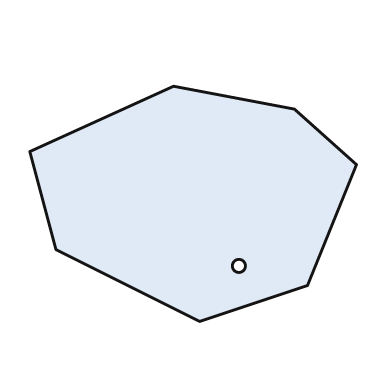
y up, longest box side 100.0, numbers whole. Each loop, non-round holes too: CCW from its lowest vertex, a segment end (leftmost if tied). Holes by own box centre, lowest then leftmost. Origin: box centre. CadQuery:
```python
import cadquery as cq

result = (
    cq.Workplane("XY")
    .moveTo(2.0, -36.0)
    .lineTo(35.0, -25.0)
    .lineTo(50.0, 12.0)
    .lineTo(31.0, 29.0)
    .lineTo(-6.0, 36.0)
    .lineTo(-50.0, 16.0)
    .lineTo(-42.0, -14.0)
    .close()
    .moveTo(14.0, -19.0)
    .circle(2.0)
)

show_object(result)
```